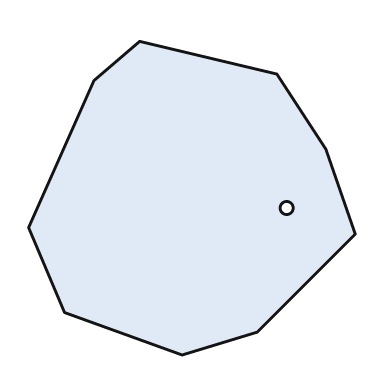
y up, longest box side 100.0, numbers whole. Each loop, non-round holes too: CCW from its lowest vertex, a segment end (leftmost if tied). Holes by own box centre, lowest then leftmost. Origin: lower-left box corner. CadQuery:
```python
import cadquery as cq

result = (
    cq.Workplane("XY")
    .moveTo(47.0, 0.0)
    .lineTo(70.0, 7.0)
    .lineTo(100.0, 37.0)
    .lineTo(91.0, 63.0)
    .lineTo(76.0, 86.0)
    .lineTo(34.0, 96.0)
    .lineTo(20.0, 84.0)
    .lineTo(0.0, 39.0)
    .lineTo(11.0, 13.0)
    .close()
    .moveTo(79.0, 45.0)
    .circle(2.0)
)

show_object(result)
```